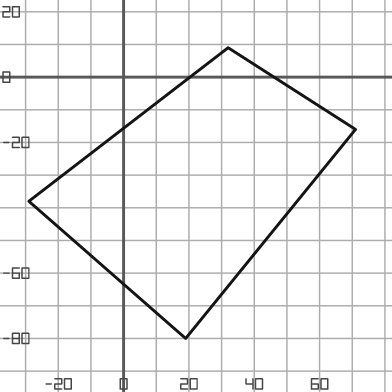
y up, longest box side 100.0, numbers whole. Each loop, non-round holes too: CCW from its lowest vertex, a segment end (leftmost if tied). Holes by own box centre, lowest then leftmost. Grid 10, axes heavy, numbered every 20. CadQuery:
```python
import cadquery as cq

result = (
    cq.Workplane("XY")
    .moveTo(19.0, -80.0)
    .lineTo(71.0, -16.0)
    .lineTo(32.0, 9.0)
    .lineTo(-29.0, -38.0)
    .close()
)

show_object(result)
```